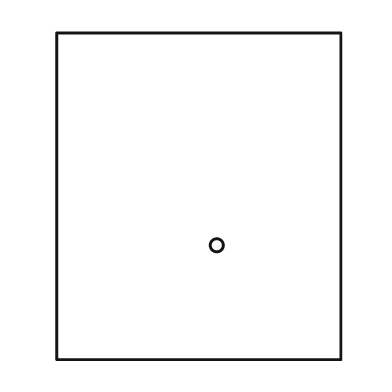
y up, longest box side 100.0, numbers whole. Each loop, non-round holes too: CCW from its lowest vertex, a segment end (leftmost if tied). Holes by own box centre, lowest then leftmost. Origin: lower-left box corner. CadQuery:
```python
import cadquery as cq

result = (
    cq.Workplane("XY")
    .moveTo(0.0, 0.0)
    .lineTo(87.0, 0.0)
    .lineTo(87.0, 100.0)
    .lineTo(0.0, 100.0)
    .close()
    .moveTo(49.0, 35.0)
    .circle(2.0)
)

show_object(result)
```